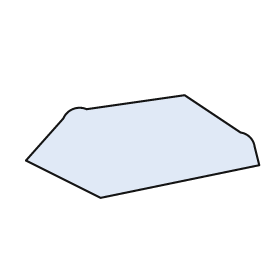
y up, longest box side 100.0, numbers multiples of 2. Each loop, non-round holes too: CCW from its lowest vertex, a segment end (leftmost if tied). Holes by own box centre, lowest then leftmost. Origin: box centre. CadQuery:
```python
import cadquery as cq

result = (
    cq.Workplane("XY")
    .moveTo(-18.0, -22.0)
    .lineTo(50.0, -8.0)
    .lineTo(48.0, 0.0)
    .threePointArc((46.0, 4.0), (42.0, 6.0))
    .lineTo(18.0, 22.0)
    .lineTo(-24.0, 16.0)
    .threePointArc((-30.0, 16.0), (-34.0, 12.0))
    .lineTo(-50.0, -6.0)
    .close()
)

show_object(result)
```